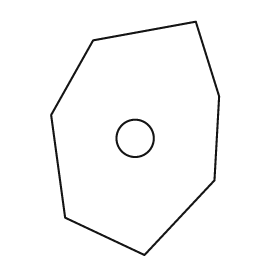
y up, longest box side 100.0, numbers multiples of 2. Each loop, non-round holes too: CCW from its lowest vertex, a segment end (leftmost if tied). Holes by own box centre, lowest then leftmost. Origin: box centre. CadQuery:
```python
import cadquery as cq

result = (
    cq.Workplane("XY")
    .moveTo(4.0, -50.0)
    .lineTo(34.0, -18.0)
    .lineTo(36.0, 18.0)
    .lineTo(26.0, 50.0)
    .lineTo(-18.0, 42.0)
    .lineTo(-36.0, 10.0)
    .lineTo(-30.0, -34.0)
    .close()
    .moveTo(0.0, 0.0)
    .circle(8.0)
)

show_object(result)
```